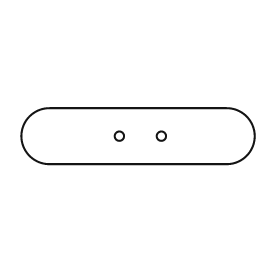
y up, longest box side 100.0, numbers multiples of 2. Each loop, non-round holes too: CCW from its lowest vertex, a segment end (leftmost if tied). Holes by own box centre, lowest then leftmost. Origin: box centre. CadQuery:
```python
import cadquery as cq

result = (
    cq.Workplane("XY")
    .moveTo(-38.0, -12.0)
    .lineTo(38.0, -12.0)
    .threePointArc((50.0, 0.0), (38.0, 12.0))
    .lineTo(-38.0, 12.0)
    .threePointArc((-50.0, 0.0), (-38.0, -12.0))
    .close()
    .moveTo(-8.0, 0.0)
    .circle(2.0)
    .moveTo(10.0, 0.0)
    .circle(2.0)
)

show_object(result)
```